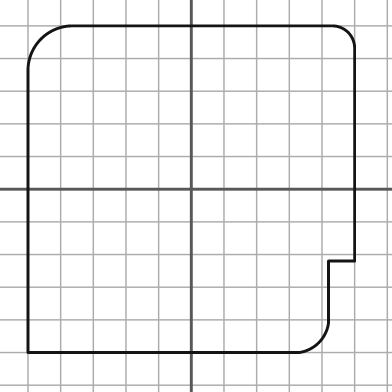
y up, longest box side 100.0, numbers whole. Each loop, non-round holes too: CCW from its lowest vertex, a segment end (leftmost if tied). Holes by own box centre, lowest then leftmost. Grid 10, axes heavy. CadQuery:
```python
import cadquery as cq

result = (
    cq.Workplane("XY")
    .moveTo(-50.0, -50.0)
    .lineTo(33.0, -50.0)
    .threePointArc((39.0, -47.0), (42.0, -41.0))
    .lineTo(42.0, -22.0)
    .lineTo(50.0, -22.0)
    .lineTo(50.0, 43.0)
    .threePointArc((48.0, 48.0), (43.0, 50.0))
    .lineTo(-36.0, 50.0)
    .threePointArc((-46.0, 46.0), (-50.0, 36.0))
    .close()
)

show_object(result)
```